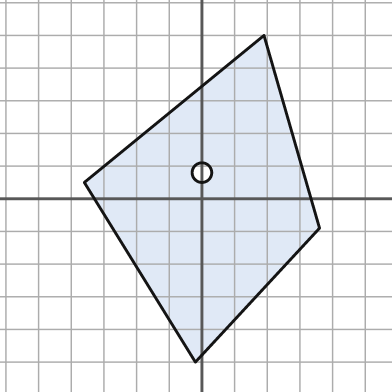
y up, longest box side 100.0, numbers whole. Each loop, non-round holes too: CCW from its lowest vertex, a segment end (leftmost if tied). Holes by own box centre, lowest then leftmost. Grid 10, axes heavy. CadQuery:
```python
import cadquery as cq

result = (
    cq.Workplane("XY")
    .moveTo(-2.0, -50.0)
    .lineTo(36.0, -9.0)
    .lineTo(19.0, 50.0)
    .lineTo(-36.0, 5.0)
    .close()
    .moveTo(0.0, 8.0)
    .circle(3.0)
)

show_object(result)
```